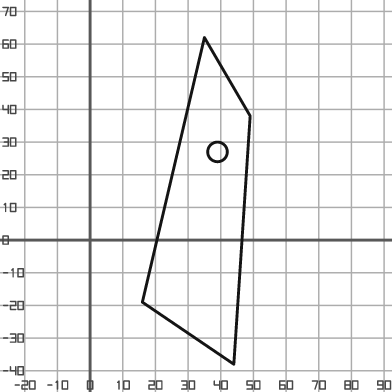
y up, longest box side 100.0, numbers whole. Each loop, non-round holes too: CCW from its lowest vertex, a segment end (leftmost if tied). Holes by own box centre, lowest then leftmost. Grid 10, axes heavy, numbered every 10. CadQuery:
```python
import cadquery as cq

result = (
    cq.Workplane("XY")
    .moveTo(44.0, -38.0)
    .lineTo(49.0, 38.0)
    .lineTo(35.0, 62.0)
    .lineTo(16.0, -19.0)
    .close()
    .moveTo(39.0, 27.0)
    .circle(3.0)
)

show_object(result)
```